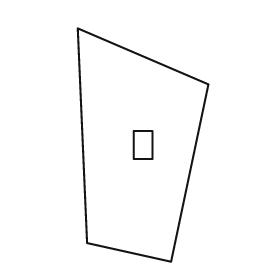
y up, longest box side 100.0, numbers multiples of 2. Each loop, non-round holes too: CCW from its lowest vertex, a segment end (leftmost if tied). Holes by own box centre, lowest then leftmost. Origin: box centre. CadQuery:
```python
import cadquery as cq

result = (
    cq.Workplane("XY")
    .moveTo(12.0, -50.0)
    .lineTo(28.0, 26.0)
    .lineTo(-28.0, 50.0)
    .lineTo(-24.0, -42.0)
    .close()
    .moveTo(-4.0, -6.0)
    .lineTo(4.0, -6.0)
    .lineTo(4.0, 6.0)
    .lineTo(-4.0, 6.0)
    .close()
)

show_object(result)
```